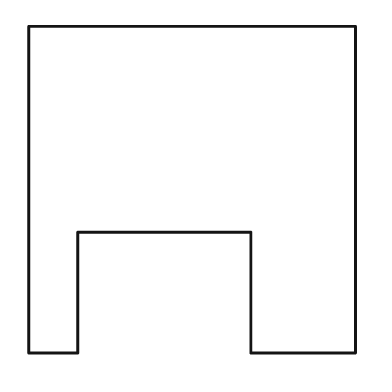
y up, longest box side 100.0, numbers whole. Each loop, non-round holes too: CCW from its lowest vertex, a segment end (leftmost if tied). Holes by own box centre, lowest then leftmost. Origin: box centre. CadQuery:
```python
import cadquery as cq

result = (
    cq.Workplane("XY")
    .moveTo(-50.0, -50.0)
    .lineTo(-35.0, -50.0)
    .lineTo(-35.0, -13.0)
    .lineTo(18.0, -13.0)
    .lineTo(18.0, -50.0)
    .lineTo(50.0, -50.0)
    .lineTo(50.0, 50.0)
    .lineTo(-50.0, 50.0)
    .close()
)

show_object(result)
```